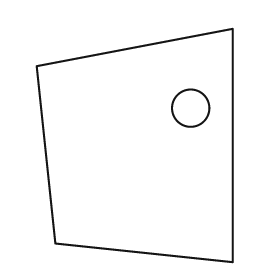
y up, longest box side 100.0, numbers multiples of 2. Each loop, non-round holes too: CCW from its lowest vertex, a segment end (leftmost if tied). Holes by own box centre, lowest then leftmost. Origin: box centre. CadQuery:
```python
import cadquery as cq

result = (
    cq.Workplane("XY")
    .moveTo(42.0, -50.0)
    .lineTo(42.0, 50.0)
    .lineTo(-42.0, 34.0)
    .lineTo(-34.0, -42.0)
    .close()
    .moveTo(24.0, 16.0)
    .circle(8.0)
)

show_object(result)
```